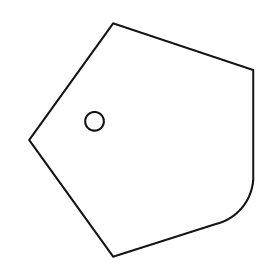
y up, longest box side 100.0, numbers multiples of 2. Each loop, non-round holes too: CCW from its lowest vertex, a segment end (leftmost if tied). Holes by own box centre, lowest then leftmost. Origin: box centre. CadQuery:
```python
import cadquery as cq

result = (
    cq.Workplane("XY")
    .moveTo(-12.0, -50.0)
    .lineTo(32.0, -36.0)
    .threePointArc((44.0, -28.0), (48.0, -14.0))
    .lineTo(48.0, 30.0)
    .lineTo(-12.0, 50.0)
    .lineTo(-48.0, 0.0)
    .close()
    .moveTo(-20.0, 8.0)
    .circle(4.0)
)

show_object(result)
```